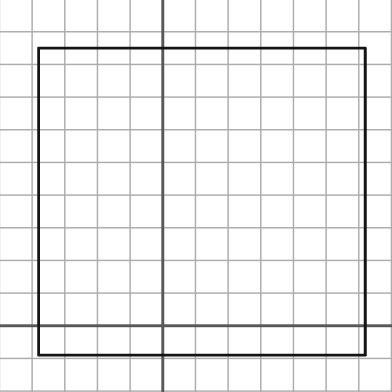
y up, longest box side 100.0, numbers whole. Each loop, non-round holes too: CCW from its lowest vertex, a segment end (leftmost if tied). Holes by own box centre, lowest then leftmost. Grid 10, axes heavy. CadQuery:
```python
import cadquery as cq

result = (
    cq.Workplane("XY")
    .moveTo(-38.0, -9.0)
    .lineTo(62.0, -9.0)
    .lineTo(62.0, 85.0)
    .lineTo(-38.0, 85.0)
    .close()
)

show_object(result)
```